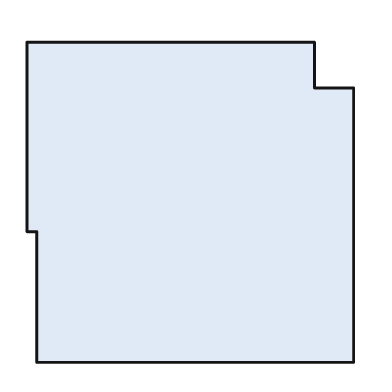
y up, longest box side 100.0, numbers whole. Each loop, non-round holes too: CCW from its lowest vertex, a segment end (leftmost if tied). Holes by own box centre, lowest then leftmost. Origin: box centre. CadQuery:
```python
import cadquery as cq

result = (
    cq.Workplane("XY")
    .moveTo(-47.0, -49.0)
    .lineTo(50.0, -49.0)
    .lineTo(50.0, 35.0)
    .lineTo(38.0, 35.0)
    .lineTo(38.0, 49.0)
    .lineTo(-50.0, 49.0)
    .lineTo(-50.0, -9.0)
    .lineTo(-47.0, -9.0)
    .close()
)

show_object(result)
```